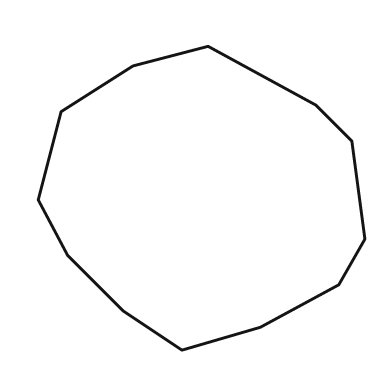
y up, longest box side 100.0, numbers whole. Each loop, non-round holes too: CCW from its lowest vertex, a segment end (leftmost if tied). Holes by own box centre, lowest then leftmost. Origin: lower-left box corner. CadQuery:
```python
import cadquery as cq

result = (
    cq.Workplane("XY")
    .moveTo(44.0, 0.0)
    .lineTo(68.0, 7.0)
    .lineTo(92.0, 20.0)
    .lineTo(100.0, 34.0)
    .lineTo(96.0, 64.0)
    .lineTo(85.0, 75.0)
    .lineTo(52.0, 93.0)
    .lineTo(29.0, 87.0)
    .lineTo(7.0, 73.0)
    .lineTo(0.0, 46.0)
    .lineTo(9.0, 29.0)
    .lineTo(26.0, 12.0)
    .close()
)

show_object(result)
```